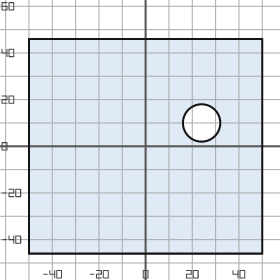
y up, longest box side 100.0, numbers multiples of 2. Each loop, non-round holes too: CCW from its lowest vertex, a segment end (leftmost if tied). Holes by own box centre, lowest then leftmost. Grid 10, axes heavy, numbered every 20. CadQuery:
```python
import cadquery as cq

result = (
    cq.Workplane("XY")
    .moveTo(-50.0, -46.0)
    .lineTo(50.0, -46.0)
    .lineTo(50.0, 46.0)
    .lineTo(-50.0, 46.0)
    .close()
    .moveTo(24.0, 10.0)
    .circle(8.0)
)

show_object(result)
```